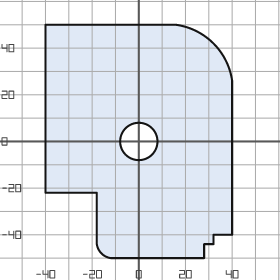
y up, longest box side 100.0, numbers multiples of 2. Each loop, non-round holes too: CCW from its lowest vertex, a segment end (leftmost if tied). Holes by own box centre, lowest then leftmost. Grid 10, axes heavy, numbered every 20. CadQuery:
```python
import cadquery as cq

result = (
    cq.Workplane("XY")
    .moveTo(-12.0, -50.0)
    .lineTo(28.0, -50.0)
    .lineTo(28.0, -44.0)
    .lineTo(32.0, -44.0)
    .lineTo(32.0, -40.0)
    .lineTo(40.0, -40.0)
    .lineTo(40.0, 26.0)
    .threePointArc((32.0, 42.0), (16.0, 50.0))
    .lineTo(-40.0, 50.0)
    .lineTo(-40.0, -22.0)
    .lineTo(-18.0, -22.0)
    .lineTo(-18.0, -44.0)
    .threePointArc((-16.0, -48.0), (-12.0, -50.0))
    .close()
    .moveTo(0.0, 0.0)
    .circle(8.0)
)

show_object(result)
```